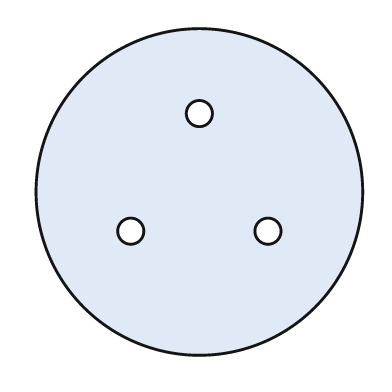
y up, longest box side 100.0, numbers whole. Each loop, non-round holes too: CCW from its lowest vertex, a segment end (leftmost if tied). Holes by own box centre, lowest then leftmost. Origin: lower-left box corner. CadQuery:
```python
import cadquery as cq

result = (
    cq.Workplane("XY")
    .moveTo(50.0, 50.0)
    .circle(50.0)
    .moveTo(29.0, 38.0)
    .circle(4.0)
    .moveTo(71.0, 38.0)
    .circle(4.0)
    .moveTo(50.0, 74.0)
    .circle(4.0)
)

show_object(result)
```